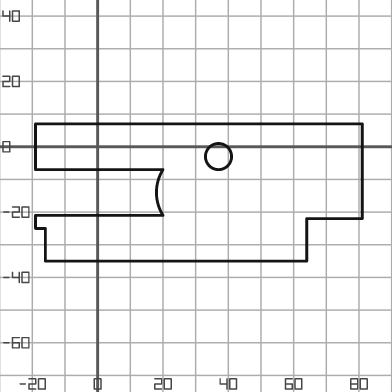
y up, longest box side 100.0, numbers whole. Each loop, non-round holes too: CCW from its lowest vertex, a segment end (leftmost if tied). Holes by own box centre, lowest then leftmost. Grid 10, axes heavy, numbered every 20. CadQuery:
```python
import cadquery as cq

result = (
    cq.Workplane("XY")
    .moveTo(-16.0, -35.0)
    .lineTo(64.0, -35.0)
    .lineTo(64.0, -22.0)
    .lineTo(81.0, -22.0)
    .lineTo(81.0, 7.0)
    .lineTo(-19.0, 7.0)
    .lineTo(-19.0, -7.0)
    .lineTo(20.0, -7.0)
    .threePointArc((18.0, -14.0), (20.0, -21.0))
    .lineTo(-19.0, -21.0)
    .lineTo(-19.0, -25.0)
    .lineTo(-16.0, -25.0)
    .close()
    .moveTo(37.0, -3.0)
    .circle(4.0)
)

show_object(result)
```